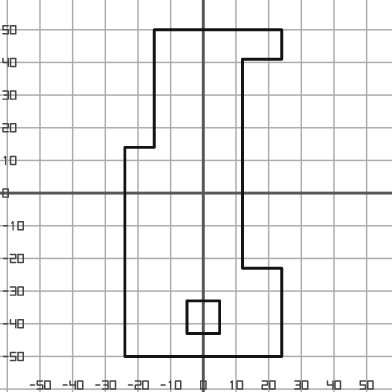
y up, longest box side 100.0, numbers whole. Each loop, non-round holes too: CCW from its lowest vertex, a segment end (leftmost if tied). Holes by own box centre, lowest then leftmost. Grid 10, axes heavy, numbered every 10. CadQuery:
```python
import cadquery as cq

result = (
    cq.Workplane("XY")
    .moveTo(-24.0, -50.0)
    .lineTo(24.0, -50.0)
    .lineTo(24.0, -23.0)
    .lineTo(12.0, -23.0)
    .lineTo(12.0, 41.0)
    .lineTo(24.0, 41.0)
    .lineTo(24.0, 50.0)
    .lineTo(-15.0, 50.0)
    .lineTo(-15.0, 14.0)
    .lineTo(-24.0, 14.0)
    .close()
    .moveTo(-5.0, -43.0)
    .lineTo(5.0, -43.0)
    .lineTo(5.0, -33.0)
    .lineTo(-5.0, -33.0)
    .close()
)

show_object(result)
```